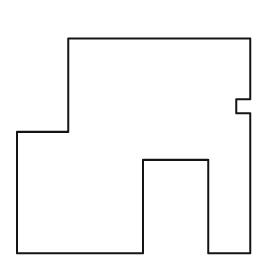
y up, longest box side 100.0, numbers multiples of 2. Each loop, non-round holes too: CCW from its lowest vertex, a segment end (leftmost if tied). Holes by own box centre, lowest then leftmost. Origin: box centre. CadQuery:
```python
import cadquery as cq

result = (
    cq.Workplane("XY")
    .moveTo(-50.0, -46.0)
    .lineTo(4.0, -46.0)
    .lineTo(4.0, -6.0)
    .lineTo(32.0, -6.0)
    .lineTo(32.0, -46.0)
    .lineTo(50.0, -46.0)
    .lineTo(50.0, 14.0)
    .lineTo(44.0, 14.0)
    .lineTo(44.0, 20.0)
    .lineTo(50.0, 20.0)
    .lineTo(50.0, 46.0)
    .lineTo(-28.0, 46.0)
    .lineTo(-28.0, 6.0)
    .lineTo(-50.0, 6.0)
    .close()
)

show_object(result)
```